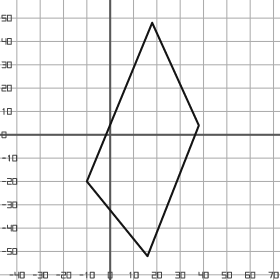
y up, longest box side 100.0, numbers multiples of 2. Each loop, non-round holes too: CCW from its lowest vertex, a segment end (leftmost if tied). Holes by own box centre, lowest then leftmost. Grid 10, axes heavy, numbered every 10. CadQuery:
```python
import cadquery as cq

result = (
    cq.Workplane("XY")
    .moveTo(16.0, -52.0)
    .lineTo(38.0, 4.0)
    .lineTo(18.0, 48.0)
    .lineTo(-10.0, -20.0)
    .close()
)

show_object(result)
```